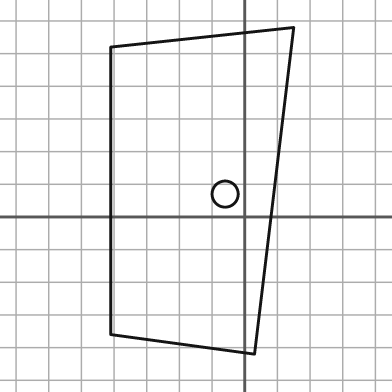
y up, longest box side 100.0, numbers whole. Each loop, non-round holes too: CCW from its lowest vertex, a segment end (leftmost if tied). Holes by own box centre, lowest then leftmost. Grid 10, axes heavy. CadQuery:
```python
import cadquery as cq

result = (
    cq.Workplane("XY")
    .moveTo(3.0, -42.0)
    .lineTo(15.0, 58.0)
    .lineTo(-41.0, 52.0)
    .lineTo(-41.0, -36.0)
    .close()
    .moveTo(-6.0, 7.0)
    .circle(4.0)
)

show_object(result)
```